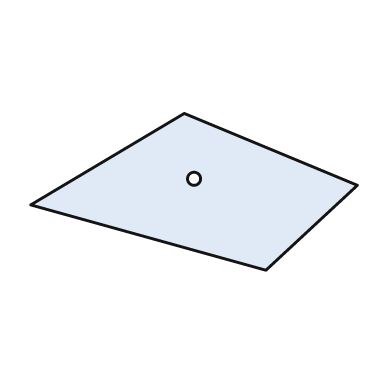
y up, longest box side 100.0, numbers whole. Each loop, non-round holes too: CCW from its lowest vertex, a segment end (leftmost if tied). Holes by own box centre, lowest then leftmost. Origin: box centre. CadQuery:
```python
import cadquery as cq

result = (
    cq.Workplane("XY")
    .moveTo(22.0, -24.0)
    .lineTo(50.0, 2.0)
    .lineTo(-3.0, 24.0)
    .lineTo(-50.0, -4.0)
    .close()
    .moveTo(0.0, 4.0)
    .circle(2.0)
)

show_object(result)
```